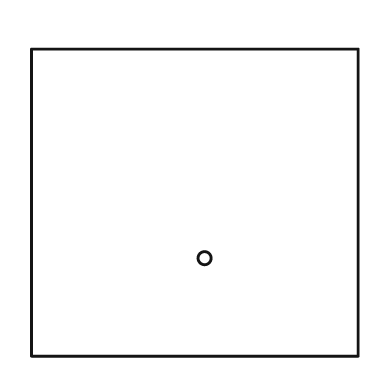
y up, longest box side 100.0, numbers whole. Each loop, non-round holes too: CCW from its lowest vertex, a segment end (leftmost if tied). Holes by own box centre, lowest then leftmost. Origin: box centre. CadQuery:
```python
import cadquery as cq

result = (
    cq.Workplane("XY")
    .moveTo(-50.0, -47.0)
    .lineTo(50.0, -47.0)
    .lineTo(50.0, 47.0)
    .lineTo(-50.0, 47.0)
    .close()
    .moveTo(3.0, -17.0)
    .circle(2.0)
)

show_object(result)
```